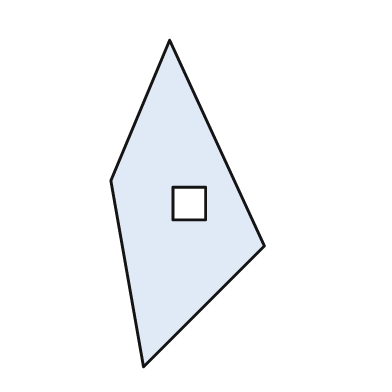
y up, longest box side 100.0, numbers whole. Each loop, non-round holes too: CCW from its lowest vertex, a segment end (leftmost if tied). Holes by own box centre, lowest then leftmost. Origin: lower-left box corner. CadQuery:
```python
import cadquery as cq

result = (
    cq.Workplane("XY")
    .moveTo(10.0, 0.0)
    .lineTo(47.0, 37.0)
    .lineTo(18.0, 100.0)
    .lineTo(0.0, 57.0)
    .close()
    .moveTo(19.0, 45.0)
    .lineTo(29.0, 45.0)
    .lineTo(29.0, 55.0)
    .lineTo(19.0, 55.0)
    .close()
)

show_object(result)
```